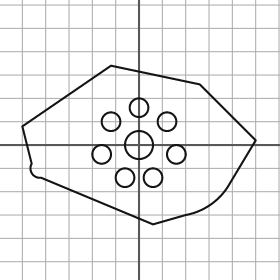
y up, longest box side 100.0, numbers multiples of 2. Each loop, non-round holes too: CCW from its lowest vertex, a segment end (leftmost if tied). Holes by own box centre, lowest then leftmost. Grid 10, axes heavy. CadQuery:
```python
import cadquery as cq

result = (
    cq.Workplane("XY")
    .moveTo(6.0, -34.0)
    .lineTo(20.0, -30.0)
    .threePointArc((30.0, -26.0), (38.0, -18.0))
    .lineTo(50.0, 2.0)
    .lineTo(26.0, 26.0)
    .lineTo(-12.0, 34.0)
    .lineTo(-50.0, 8.0)
    .lineTo(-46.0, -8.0)
    .threePointArc((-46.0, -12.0), (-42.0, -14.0))
    .close()
    .moveTo(-6.0, -14.0)
    .circle(4.0)
    .moveTo(6.0, -14.0)
    .circle(4.0)
    .moveTo(-16.0, -4.0)
    .circle(4.0)
    .moveTo(16.0, -4.0)
    .circle(4.0)
    .moveTo(0.0, 0.0)
    .circle(6.0)
    .moveTo(-12.0, 10.0)
    .circle(4.0)
    .moveTo(12.0, 10.0)
    .circle(4.0)
    .moveTo(0.0, 16.0)
    .circle(4.0)
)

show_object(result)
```